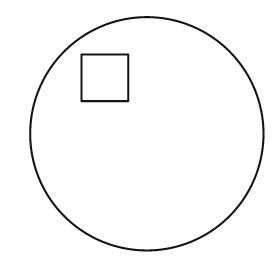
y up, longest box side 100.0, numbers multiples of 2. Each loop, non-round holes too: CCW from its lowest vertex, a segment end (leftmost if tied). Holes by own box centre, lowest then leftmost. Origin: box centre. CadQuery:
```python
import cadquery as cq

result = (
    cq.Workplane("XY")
    .moveTo(0.0, 0.0)
    .circle(50.0)
    .moveTo(-28.0, 14.0)
    .lineTo(-8.0, 14.0)
    .lineTo(-8.0, 34.0)
    .lineTo(-28.0, 34.0)
    .close()
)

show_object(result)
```